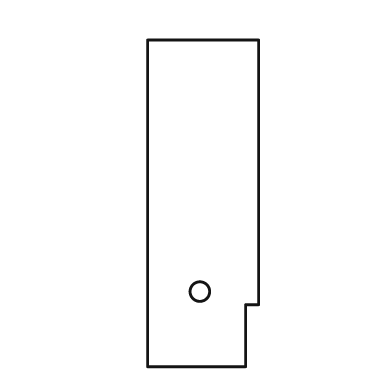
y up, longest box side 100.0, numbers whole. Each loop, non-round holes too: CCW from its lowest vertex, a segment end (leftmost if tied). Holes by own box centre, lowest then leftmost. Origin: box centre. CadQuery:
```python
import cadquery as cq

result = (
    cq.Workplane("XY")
    .moveTo(-17.0, -50.0)
    .lineTo(13.0, -50.0)
    .lineTo(13.0, -31.0)
    .lineTo(17.0, -31.0)
    .lineTo(17.0, 50.0)
    .lineTo(-17.0, 50.0)
    .close()
    .moveTo(-1.0, -27.0)
    .circle(3.0)
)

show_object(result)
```